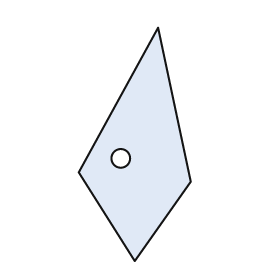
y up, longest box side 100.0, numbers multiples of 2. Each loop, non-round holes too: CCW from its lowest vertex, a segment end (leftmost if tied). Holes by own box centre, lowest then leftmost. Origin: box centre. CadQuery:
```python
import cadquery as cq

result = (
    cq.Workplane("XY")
    .moveTo(0.0, -50.0)
    .lineTo(24.0, -16.0)
    .lineTo(10.0, 50.0)
    .lineTo(-24.0, -12.0)
    .close()
    .moveTo(-6.0, -6.0)
    .circle(4.0)
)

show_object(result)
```